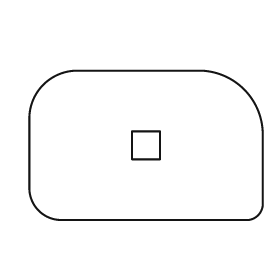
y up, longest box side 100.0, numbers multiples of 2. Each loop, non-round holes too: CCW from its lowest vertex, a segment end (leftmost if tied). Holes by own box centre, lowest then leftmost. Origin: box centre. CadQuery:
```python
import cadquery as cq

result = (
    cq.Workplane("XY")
    .moveTo(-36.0, -32.0)
    .lineTo(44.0, -32.0)
    .threePointArc((48.0, -30.0), (50.0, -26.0))
    .lineTo(50.0, 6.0)
    .threePointArc((42.0, 24.0), (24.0, 32.0))
    .lineTo(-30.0, 32.0)
    .threePointArc((-44.0, 26.0), (-50.0, 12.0))
    .lineTo(-50.0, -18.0)
    .threePointArc((-46.0, -28.0), (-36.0, -32.0))
    .close()
    .moveTo(-6.0, -6.0)
    .lineTo(6.0, -6.0)
    .lineTo(6.0, 6.0)
    .lineTo(-6.0, 6.0)
    .close()
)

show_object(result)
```